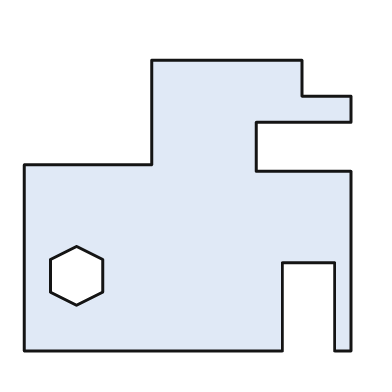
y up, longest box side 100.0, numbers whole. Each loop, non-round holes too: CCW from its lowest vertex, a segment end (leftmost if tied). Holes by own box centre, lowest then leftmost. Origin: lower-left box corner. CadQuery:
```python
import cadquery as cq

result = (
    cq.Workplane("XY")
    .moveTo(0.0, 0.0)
    .lineTo(79.0, 0.0)
    .lineTo(79.0, 27.0)
    .lineTo(95.0, 27.0)
    .lineTo(95.0, 0.0)
    .lineTo(100.0, 0.0)
    .lineTo(100.0, 55.0)
    .lineTo(71.0, 55.0)
    .lineTo(71.0, 70.0)
    .lineTo(100.0, 70.0)
    .lineTo(100.0, 78.0)
    .lineTo(85.0, 78.0)
    .lineTo(85.0, 89.0)
    .lineTo(39.0, 89.0)
    .lineTo(39.0, 57.0)
    .lineTo(0.0, 57.0)
    .close()
    .moveTo(16.0, 14.0)
    .lineTo(24.0, 18.0)
    .lineTo(24.0, 28.0)
    .lineTo(16.0, 32.0)
    .lineTo(8.0, 28.0)
    .lineTo(8.0, 18.0)
    .close()
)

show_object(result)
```